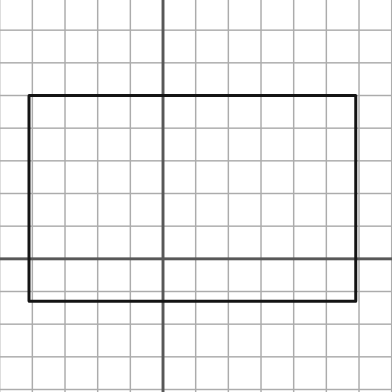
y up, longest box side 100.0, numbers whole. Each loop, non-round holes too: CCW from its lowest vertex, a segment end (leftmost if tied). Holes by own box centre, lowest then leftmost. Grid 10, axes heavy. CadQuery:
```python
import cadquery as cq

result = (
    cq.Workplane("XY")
    .moveTo(-41.0, -13.0)
    .lineTo(59.0, -13.0)
    .lineTo(59.0, 50.0)
    .lineTo(-41.0, 50.0)
    .close()
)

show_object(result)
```